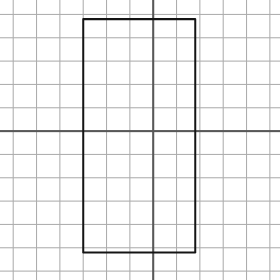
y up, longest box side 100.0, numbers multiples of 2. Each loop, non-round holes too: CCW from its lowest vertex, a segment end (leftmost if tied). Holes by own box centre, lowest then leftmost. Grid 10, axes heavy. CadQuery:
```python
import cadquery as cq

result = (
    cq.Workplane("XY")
    .moveTo(-30.0, -52.0)
    .lineTo(18.0, -52.0)
    .lineTo(18.0, 48.0)
    .lineTo(-30.0, 48.0)
    .close()
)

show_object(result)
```